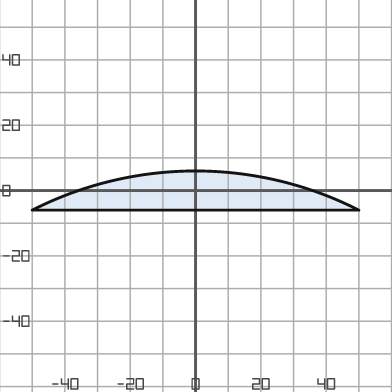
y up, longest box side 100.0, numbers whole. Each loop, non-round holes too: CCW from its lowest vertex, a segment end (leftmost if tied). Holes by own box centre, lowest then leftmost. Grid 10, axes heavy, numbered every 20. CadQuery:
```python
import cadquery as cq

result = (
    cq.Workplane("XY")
    .moveTo(-50.0, -6.0)
    .lineTo(50.0, -6.0)
    .threePointArc((0.0, 6.0), (-50.0, -6.0))
    .close()
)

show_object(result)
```